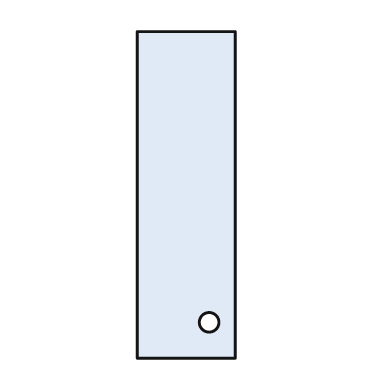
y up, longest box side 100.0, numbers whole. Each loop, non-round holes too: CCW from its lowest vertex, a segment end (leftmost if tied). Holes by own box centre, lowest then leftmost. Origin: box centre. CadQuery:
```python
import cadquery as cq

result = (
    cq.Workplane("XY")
    .moveTo(-15.0, -50.0)
    .lineTo(15.0, -50.0)
    .lineTo(15.0, 50.0)
    .lineTo(-15.0, 50.0)
    .close()
    .moveTo(7.0, -39.0)
    .circle(3.0)
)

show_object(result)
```